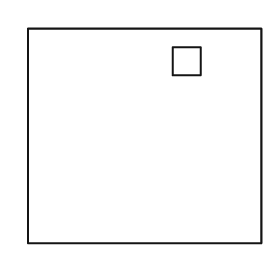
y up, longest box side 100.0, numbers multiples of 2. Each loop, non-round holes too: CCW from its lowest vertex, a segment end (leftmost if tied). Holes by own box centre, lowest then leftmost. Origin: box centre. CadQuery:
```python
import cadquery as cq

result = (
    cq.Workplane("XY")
    .moveTo(-50.0, -46.0)
    .lineTo(50.0, -46.0)
    .lineTo(50.0, 46.0)
    .lineTo(-50.0, 46.0)
    .close()
    .moveTo(12.0, 26.0)
    .lineTo(24.0, 26.0)
    .lineTo(24.0, 38.0)
    .lineTo(12.0, 38.0)
    .close()
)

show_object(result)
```